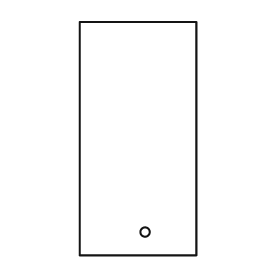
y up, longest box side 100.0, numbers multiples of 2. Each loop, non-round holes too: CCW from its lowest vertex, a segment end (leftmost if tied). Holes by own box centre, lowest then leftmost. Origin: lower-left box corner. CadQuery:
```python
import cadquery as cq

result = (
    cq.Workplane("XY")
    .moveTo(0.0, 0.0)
    .lineTo(50.0, 0.0)
    .lineTo(50.0, 100.0)
    .lineTo(0.0, 100.0)
    .close()
    .moveTo(28.0, 10.0)
    .circle(2.0)
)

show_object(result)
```